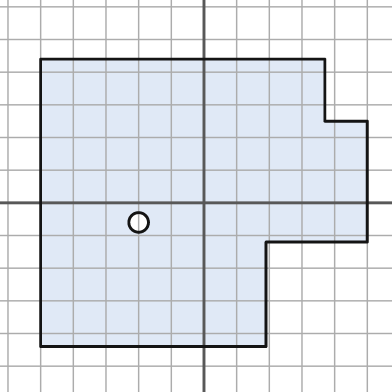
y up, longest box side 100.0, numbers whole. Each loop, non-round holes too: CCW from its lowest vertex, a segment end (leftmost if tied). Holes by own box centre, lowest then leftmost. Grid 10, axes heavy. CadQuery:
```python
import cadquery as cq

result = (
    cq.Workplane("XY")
    .moveTo(-50.0, -44.0)
    .lineTo(19.0, -44.0)
    .lineTo(19.0, -12.0)
    .lineTo(50.0, -12.0)
    .lineTo(50.0, 25.0)
    .lineTo(37.0, 25.0)
    .lineTo(37.0, 44.0)
    .lineTo(-50.0, 44.0)
    .close()
    .moveTo(-20.0, -6.0)
    .circle(3.0)
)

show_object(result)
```